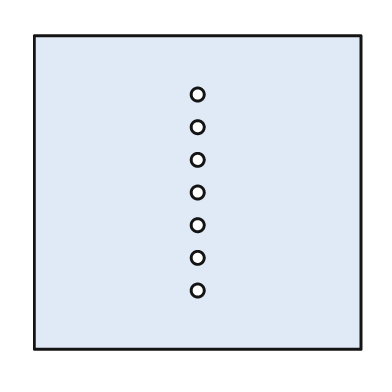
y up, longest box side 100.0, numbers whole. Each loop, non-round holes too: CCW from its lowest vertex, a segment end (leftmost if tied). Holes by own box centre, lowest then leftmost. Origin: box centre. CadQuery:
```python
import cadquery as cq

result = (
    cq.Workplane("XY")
    .moveTo(-50.0, -48.0)
    .lineTo(50.0, -48.0)
    .lineTo(50.0, 48.0)
    .lineTo(-50.0, 48.0)
    .close()
    .moveTo(0.0, -30.0)
    .circle(2.0)
    .moveTo(0.0, -20.0)
    .circle(2.0)
    .moveTo(0.0, -10.0)
    .circle(2.0)
    .moveTo(0.0, 0.0)
    .circle(2.0)
    .moveTo(0.0, 10.0)
    .circle(2.0)
    .moveTo(0.0, 20.0)
    .circle(2.0)
    .moveTo(0.0, 30.0)
    .circle(2.0)
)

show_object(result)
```